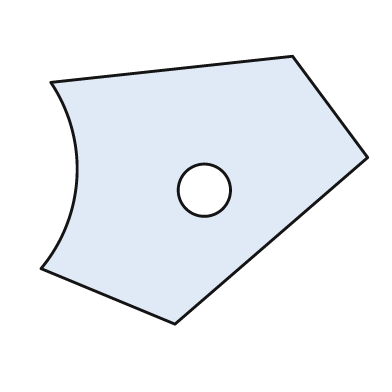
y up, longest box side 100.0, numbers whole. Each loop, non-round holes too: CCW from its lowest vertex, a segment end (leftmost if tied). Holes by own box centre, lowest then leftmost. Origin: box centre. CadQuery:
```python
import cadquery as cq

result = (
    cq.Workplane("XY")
    .moveTo(-9.0, -41.0)
    .lineTo(50.0, 10.0)
    .lineTo(27.0, 41.0)
    .lineTo(-47.0, 33.0)
    .threePointArc((-39.0, 4.0), (-50.0, -24.0))
    .close()
    .moveTo(0.0, 0.0)
    .circle(8.0)
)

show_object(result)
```